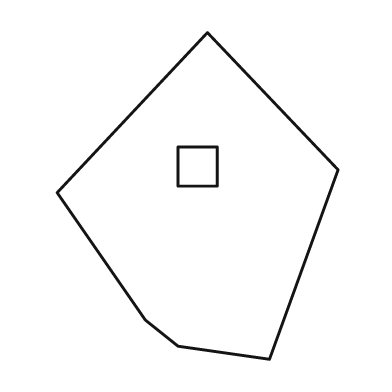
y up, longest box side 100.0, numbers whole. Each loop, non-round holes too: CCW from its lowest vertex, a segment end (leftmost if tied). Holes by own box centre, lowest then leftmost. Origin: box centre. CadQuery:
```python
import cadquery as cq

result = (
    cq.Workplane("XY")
    .moveTo(22.0, -50.0)
    .lineTo(43.0, 8.0)
    .lineTo(3.0, 50.0)
    .lineTo(-43.0, 1.0)
    .lineTo(-16.0, -38.0)
    .lineTo(-6.0, -46.0)
    .close()
    .moveTo(-6.0, 3.0)
    .lineTo(6.0, 3.0)
    .lineTo(6.0, 15.0)
    .lineTo(-6.0, 15.0)
    .close()
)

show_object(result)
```